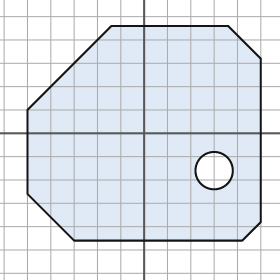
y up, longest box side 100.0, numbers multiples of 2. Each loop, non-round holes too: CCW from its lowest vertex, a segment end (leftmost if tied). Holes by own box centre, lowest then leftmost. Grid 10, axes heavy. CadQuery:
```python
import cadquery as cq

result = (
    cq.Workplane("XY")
    .moveTo(-30.0, -46.0)
    .lineTo(42.0, -46.0)
    .lineTo(50.0, -38.0)
    .lineTo(50.0, 32.0)
    .lineTo(36.0, 46.0)
    .lineTo(-14.0, 46.0)
    .lineTo(-50.0, 10.0)
    .lineTo(-50.0, -26.0)
    .close()
    .moveTo(30.0, -16.0)
    .circle(8.0)
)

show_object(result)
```